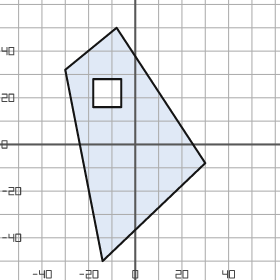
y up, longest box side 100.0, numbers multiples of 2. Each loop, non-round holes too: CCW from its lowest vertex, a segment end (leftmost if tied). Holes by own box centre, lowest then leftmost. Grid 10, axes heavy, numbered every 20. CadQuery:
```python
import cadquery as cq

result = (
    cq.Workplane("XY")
    .moveTo(-14.0, -50.0)
    .lineTo(30.0, -8.0)
    .lineTo(-8.0, 50.0)
    .lineTo(-30.0, 32.0)
    .close()
    .moveTo(-18.0, 16.0)
    .lineTo(-6.0, 16.0)
    .lineTo(-6.0, 28.0)
    .lineTo(-18.0, 28.0)
    .close()
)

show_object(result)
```